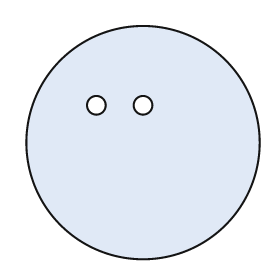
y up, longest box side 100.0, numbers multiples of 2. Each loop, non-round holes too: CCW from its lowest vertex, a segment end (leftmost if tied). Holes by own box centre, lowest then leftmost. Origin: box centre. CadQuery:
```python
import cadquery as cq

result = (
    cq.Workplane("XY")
    .moveTo(0.0, 0.0)
    .circle(50.0)
    .moveTo(-20.0, 16.0)
    .circle(4.0)
    .moveTo(0.0, 16.0)
    .circle(4.0)
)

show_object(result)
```